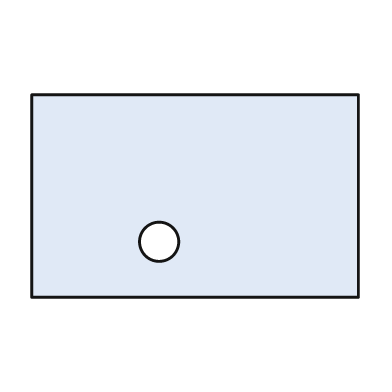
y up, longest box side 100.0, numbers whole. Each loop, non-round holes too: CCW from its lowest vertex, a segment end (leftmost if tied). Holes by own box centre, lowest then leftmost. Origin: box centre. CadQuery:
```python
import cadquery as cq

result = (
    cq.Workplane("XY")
    .moveTo(-50.0, -31.0)
    .lineTo(50.0, -31.0)
    .lineTo(50.0, 31.0)
    .lineTo(-50.0, 31.0)
    .close()
    .moveTo(-11.0, -14.0)
    .circle(6.0)
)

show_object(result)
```